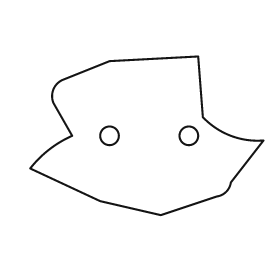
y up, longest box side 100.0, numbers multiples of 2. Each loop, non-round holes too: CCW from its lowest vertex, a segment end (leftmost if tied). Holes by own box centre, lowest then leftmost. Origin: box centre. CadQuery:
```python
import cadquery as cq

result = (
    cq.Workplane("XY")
    .moveTo(6.0, -34.0)
    .lineTo(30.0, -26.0)
    .threePointArc((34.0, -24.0), (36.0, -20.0))
    .lineTo(50.0, -2.0)
    .threePointArc((36.0, 0.0), (24.0, 8.0))
    .lineTo(22.0, 34.0)
    .lineTo(-16.0, 32.0)
    .lineTo(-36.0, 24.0)
    .threePointArc((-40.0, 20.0), (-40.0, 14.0))
    .lineTo(-32.0, 0.0)
    .threePointArc((-42.0, -6.0), (-50.0, -14.0))
    .lineTo(-20.0, -28.0)
    .close()
    .moveTo(-16.0, 0.0)
    .circle(4.0)
    .moveTo(18.0, 0.0)
    .circle(4.0)
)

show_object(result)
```